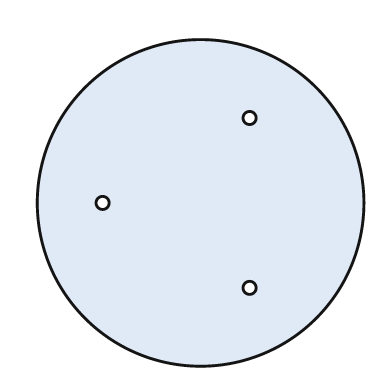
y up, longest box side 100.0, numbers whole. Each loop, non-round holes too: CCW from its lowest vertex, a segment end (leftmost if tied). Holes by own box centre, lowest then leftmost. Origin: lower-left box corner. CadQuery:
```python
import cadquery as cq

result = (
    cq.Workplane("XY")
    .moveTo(50.0, 50.0)
    .circle(50.0)
    .moveTo(65.0, 24.0)
    .circle(2.0)
    .moveTo(20.0, 50.0)
    .circle(2.0)
    .moveTo(65.0, 76.0)
    .circle(2.0)
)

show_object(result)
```